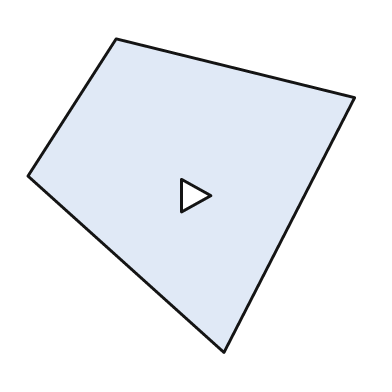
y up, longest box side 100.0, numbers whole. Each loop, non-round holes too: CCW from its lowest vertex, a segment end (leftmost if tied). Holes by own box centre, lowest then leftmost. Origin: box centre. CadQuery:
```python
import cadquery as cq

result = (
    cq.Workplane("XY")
    .moveTo(10.0, -48.0)
    .lineTo(50.0, 30.0)
    .lineTo(-23.0, 48.0)
    .lineTo(-50.0, 6.0)
    .close()
    .moveTo(-3.0, -5.0)
    .lineTo(6.0, 0.0)
    .lineTo(-3.0, 5.0)
    .close()
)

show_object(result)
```